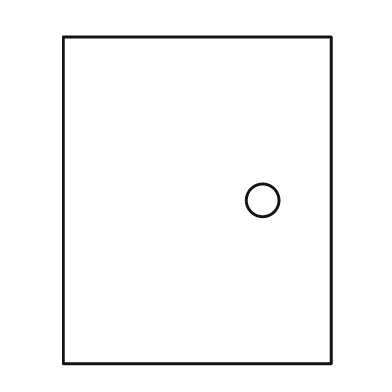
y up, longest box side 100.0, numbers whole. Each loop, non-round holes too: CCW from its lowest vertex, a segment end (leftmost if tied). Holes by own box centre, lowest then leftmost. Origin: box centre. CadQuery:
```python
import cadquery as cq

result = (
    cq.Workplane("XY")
    .moveTo(-41.0, -50.0)
    .lineTo(41.0, -50.0)
    .lineTo(41.0, 50.0)
    .lineTo(-41.0, 50.0)
    .close()
    .moveTo(20.0, 0.0)
    .circle(5.0)
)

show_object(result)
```